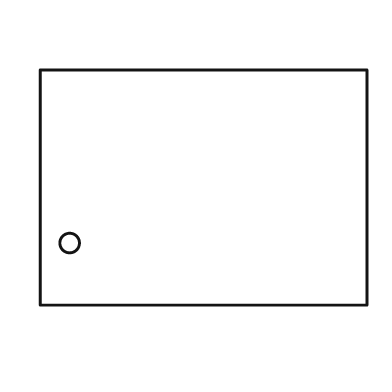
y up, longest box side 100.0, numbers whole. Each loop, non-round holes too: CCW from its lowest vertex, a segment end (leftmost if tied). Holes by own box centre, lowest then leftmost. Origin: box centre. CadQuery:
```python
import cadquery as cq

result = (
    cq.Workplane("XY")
    .moveTo(-50.0, -36.0)
    .lineTo(50.0, -36.0)
    .lineTo(50.0, 36.0)
    .lineTo(-50.0, 36.0)
    .close()
    .moveTo(-41.0, -17.0)
    .circle(3.0)
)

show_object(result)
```